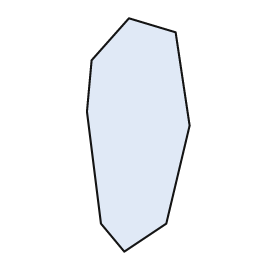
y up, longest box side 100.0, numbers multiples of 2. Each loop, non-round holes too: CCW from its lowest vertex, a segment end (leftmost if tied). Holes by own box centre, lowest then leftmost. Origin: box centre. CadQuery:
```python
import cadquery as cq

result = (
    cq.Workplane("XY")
    .moveTo(-6.0, -50.0)
    .lineTo(12.0, -38.0)
    .lineTo(22.0, 4.0)
    .lineTo(16.0, 44.0)
    .lineTo(-4.0, 50.0)
    .lineTo(-20.0, 32.0)
    .lineTo(-22.0, 10.0)
    .lineTo(-16.0, -38.0)
    .close()
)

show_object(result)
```